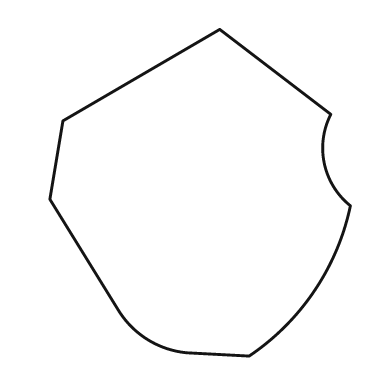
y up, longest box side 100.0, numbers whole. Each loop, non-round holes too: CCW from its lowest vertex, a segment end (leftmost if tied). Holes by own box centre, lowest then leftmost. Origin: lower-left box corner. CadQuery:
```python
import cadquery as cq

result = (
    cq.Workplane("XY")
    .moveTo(61.0, 0.0)
    .threePointArc((81.0, 20.0), (92.0, 46.0))
    .threePointArc((84.0, 59.0), (86.0, 74.0))
    .lineTo(52.0, 100.0)
    .lineTo(4.0, 72.0)
    .lineTo(0.0, 48.0)
    .lineTo(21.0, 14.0)
    .threePointArc((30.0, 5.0), (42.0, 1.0))
    .close()
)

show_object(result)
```